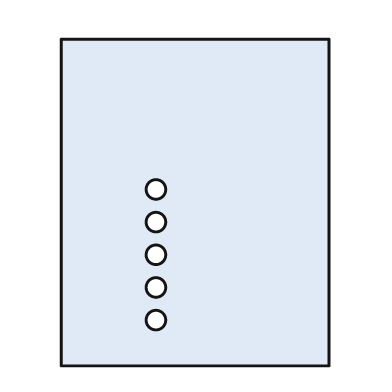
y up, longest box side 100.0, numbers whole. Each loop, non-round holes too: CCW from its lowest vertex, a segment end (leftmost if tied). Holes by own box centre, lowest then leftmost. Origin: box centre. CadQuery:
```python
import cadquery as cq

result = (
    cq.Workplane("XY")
    .moveTo(-41.0, -50.0)
    .lineTo(41.0, -50.0)
    .lineTo(41.0, 50.0)
    .lineTo(-41.0, 50.0)
    .close()
    .moveTo(-12.0, -36.0)
    .circle(3.0)
    .moveTo(-12.0, -26.0)
    .circle(3.0)
    .moveTo(-12.0, -16.0)
    .circle(3.0)
    .moveTo(-12.0, -6.0)
    .circle(3.0)
    .moveTo(-12.0, 4.0)
    .circle(3.0)
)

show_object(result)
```